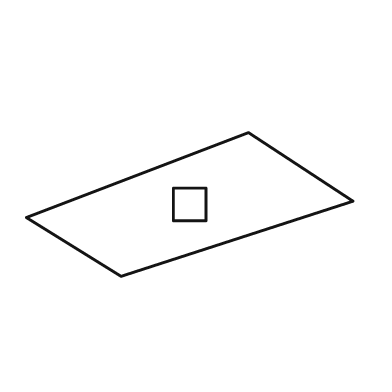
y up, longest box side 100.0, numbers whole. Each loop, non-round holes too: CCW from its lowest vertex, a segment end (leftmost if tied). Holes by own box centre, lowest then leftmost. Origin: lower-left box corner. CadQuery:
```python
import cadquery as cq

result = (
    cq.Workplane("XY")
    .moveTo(29.0, 0.0)
    .lineTo(100.0, 23.0)
    .lineTo(68.0, 44.0)
    .lineTo(0.0, 18.0)
    .close()
    .moveTo(45.0, 17.0)
    .lineTo(55.0, 17.0)
    .lineTo(55.0, 27.0)
    .lineTo(45.0, 27.0)
    .close()
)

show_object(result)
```